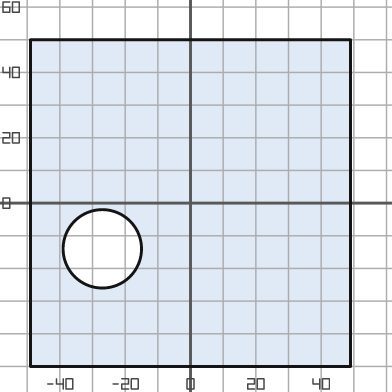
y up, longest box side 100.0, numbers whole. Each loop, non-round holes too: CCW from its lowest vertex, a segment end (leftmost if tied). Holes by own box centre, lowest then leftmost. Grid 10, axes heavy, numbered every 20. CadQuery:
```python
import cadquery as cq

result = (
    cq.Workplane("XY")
    .moveTo(-49.0, -50.0)
    .lineTo(49.0, -50.0)
    .lineTo(49.0, 50.0)
    .lineTo(-49.0, 50.0)
    .close()
    .moveTo(-27.0, -14.0)
    .circle(12.0)
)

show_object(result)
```